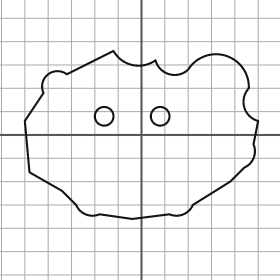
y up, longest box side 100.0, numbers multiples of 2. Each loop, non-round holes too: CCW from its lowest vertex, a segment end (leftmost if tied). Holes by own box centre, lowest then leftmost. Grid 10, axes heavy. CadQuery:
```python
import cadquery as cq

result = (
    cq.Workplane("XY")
    .moveTo(-4.0, -36.0)
    .lineTo(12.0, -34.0)
    .threePointArc((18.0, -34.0), (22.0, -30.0))
    .lineTo(38.0, -20.0)
    .lineTo(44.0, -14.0)
    .threePointArc((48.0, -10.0), (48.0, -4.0))
    .lineTo(50.0, 6.0)
    .threePointArc((44.0, 12.0), (46.0, 20.0))
    .threePointArc((36.0, 34.0), (20.0, 28.0))
    .threePointArc((12.0, 26.0), (6.0, 32.0))
    .threePointArc((-4.0, 30.0), (-12.0, 36.0))
    .lineTo(-32.0, 26.0)
    .threePointArc((-40.0, 26.0), (-42.0, 18.0))
    .lineTo(-50.0, 6.0)
    .lineTo(-48.0, -16.0)
    .lineTo(-34.0, -24.0)
    .lineTo(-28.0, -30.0)
    .threePointArc((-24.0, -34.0), (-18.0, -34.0))
    .close()
    .moveTo(-16.0, 8.0)
    .circle(4.0)
    .moveTo(8.0, 8.0)
    .circle(4.0)
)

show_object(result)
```